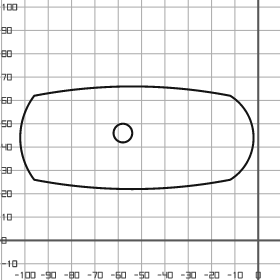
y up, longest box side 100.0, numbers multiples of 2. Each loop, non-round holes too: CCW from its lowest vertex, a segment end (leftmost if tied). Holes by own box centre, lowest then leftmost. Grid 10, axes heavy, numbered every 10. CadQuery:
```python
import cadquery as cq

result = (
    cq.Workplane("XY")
    .moveTo(-96.0, 26.0)
    .threePointArc((-54.0, 22.0), (-12.0, 26.0))
    .threePointArc((-2.0, 44.0), (-12.0, 62.0))
    .threePointArc((-54.0, 66.0), (-96.0, 62.0))
    .threePointArc((-102.0, 44.0), (-96.0, 26.0))
    .close()
    .moveTo(-58.0, 46.0)
    .circle(4.0)
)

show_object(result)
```